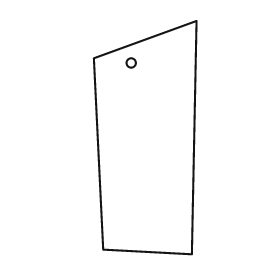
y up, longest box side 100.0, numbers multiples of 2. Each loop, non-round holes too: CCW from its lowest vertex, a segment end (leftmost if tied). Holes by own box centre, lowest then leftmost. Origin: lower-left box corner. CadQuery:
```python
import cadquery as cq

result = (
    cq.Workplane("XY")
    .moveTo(42.0, 0.0)
    .lineTo(44.0, 100.0)
    .lineTo(0.0, 84.0)
    .lineTo(4.0, 2.0)
    .close()
    .moveTo(16.0, 82.0)
    .circle(2.0)
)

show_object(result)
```